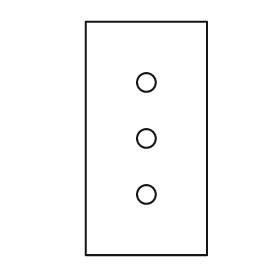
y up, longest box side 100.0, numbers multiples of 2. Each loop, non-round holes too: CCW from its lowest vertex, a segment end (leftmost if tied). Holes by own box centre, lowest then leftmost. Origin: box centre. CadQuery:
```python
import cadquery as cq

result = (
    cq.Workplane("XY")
    .moveTo(-26.0, -50.0)
    .lineTo(26.0, -50.0)
    .lineTo(26.0, 50.0)
    .lineTo(-26.0, 50.0)
    .close()
    .moveTo(0.0, -24.0)
    .circle(4.0)
    .moveTo(0.0, 0.0)
    .circle(4.0)
    .moveTo(0.0, 24.0)
    .circle(4.0)
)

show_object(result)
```